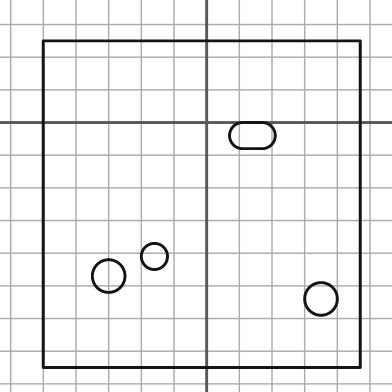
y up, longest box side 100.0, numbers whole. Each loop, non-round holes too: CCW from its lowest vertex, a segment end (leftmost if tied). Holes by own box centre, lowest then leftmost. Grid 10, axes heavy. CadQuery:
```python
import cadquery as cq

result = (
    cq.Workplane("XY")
    .moveTo(-50.0, -75.0)
    .lineTo(47.0, -75.0)
    .lineTo(47.0, 25.0)
    .lineTo(-50.0, 25.0)
    .close()
    .moveTo(35.0, -54.0)
    .circle(5.0)
    .moveTo(-30.0, -47.0)
    .circle(5.0)
    .moveTo(-16.0, -41.0)
    .circle(4.0)
    .moveTo(11.0, -8.0)
    .lineTo(17.0, -8.0)
    .threePointArc((21.0, -4.0), (17.0, 0.0))
    .lineTo(11.0, 0.0)
    .threePointArc((7.0, -4.0), (11.0, -8.0))
    .close()
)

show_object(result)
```